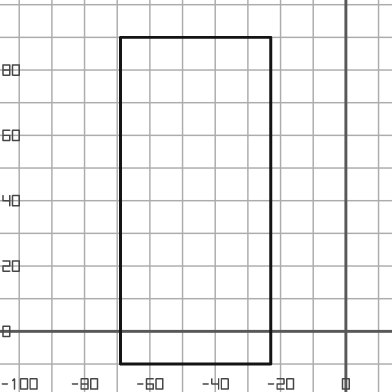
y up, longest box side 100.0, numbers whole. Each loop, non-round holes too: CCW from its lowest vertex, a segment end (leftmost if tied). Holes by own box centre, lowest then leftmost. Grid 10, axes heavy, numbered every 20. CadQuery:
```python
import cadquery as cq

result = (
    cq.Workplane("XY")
    .moveTo(-69.0, -10.0)
    .lineTo(-23.0, -10.0)
    .lineTo(-23.0, 90.0)
    .lineTo(-69.0, 90.0)
    .close()
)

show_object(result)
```